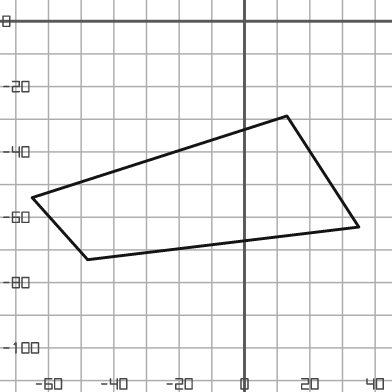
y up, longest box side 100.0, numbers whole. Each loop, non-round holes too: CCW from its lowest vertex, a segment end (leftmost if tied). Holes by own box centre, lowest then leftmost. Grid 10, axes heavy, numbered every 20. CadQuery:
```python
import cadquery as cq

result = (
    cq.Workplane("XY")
    .moveTo(-48.0, -73.0)
    .lineTo(35.0, -63.0)
    .lineTo(13.0, -29.0)
    .lineTo(-65.0, -54.0)
    .close()
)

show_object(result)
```